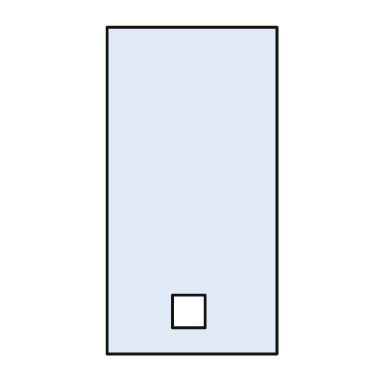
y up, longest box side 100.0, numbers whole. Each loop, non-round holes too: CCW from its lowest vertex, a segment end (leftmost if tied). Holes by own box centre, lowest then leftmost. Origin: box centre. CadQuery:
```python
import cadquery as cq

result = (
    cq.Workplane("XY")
    .moveTo(-26.0, -50.0)
    .lineTo(26.0, -50.0)
    .lineTo(26.0, 50.0)
    .lineTo(-26.0, 50.0)
    .close()
    .moveTo(-6.0, -42.0)
    .lineTo(4.0, -42.0)
    .lineTo(4.0, -32.0)
    .lineTo(-6.0, -32.0)
    .close()
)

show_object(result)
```